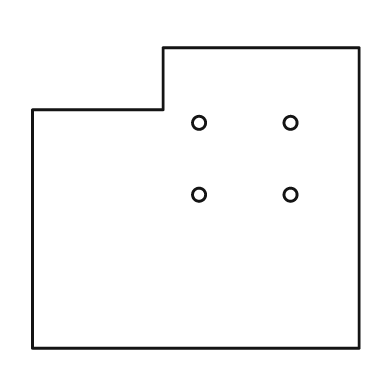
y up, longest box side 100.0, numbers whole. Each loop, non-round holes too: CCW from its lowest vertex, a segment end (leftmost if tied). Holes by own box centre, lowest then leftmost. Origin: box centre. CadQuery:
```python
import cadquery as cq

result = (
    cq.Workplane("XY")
    .moveTo(-50.0, -46.0)
    .lineTo(50.0, -46.0)
    .lineTo(50.0, 46.0)
    .lineTo(-10.0, 46.0)
    .lineTo(-10.0, 27.0)
    .lineTo(-50.0, 27.0)
    .close()
    .moveTo(1.0, 1.0)
    .circle(2.0)
    .moveTo(29.0, 1.0)
    .circle(2.0)
    .moveTo(1.0, 23.0)
    .circle(2.0)
    .moveTo(29.0, 23.0)
    .circle(2.0)
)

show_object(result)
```